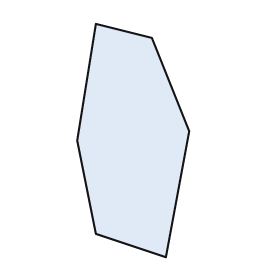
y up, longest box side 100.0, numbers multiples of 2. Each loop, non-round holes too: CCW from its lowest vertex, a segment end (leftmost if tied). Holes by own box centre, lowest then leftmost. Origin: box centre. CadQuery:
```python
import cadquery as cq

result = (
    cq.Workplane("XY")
    .moveTo(14.0, -50.0)
    .lineTo(24.0, 4.0)
    .lineTo(8.0, 44.0)
    .lineTo(-16.0, 50.0)
    .lineTo(-24.0, 0.0)
    .lineTo(-16.0, -40.0)
    .close()
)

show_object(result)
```